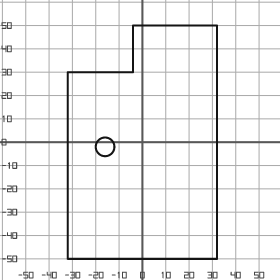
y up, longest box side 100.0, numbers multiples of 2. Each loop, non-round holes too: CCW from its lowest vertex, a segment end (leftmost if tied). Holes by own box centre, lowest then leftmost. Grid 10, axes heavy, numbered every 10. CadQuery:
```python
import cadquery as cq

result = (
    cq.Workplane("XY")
    .moveTo(-32.0, -50.0)
    .lineTo(32.0, -50.0)
    .lineTo(32.0, 50.0)
    .lineTo(-4.0, 50.0)
    .lineTo(-4.0, 30.0)
    .lineTo(-32.0, 30.0)
    .close()
    .moveTo(-16.0, -2.0)
    .circle(4.0)
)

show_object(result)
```